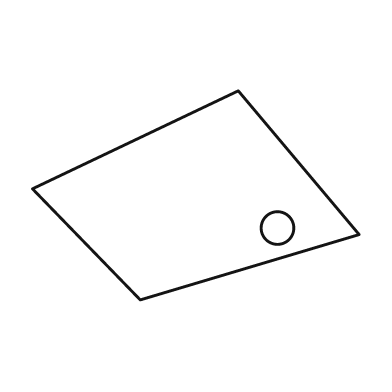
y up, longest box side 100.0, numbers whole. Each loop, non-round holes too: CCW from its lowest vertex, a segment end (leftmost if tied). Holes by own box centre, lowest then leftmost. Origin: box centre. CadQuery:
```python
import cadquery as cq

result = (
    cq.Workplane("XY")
    .moveTo(-17.0, -32.0)
    .lineTo(50.0, -12.0)
    .lineTo(13.0, 32.0)
    .lineTo(-50.0, 2.0)
    .close()
    .moveTo(25.0, -10.0)
    .circle(5.0)
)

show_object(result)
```